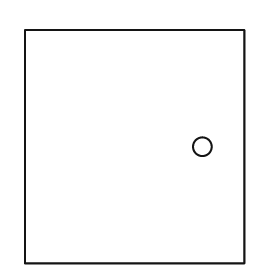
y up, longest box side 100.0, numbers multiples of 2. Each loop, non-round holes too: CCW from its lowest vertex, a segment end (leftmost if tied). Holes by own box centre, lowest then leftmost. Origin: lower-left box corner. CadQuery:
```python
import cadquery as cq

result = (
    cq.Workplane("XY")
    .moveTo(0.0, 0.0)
    .lineTo(94.0, 0.0)
    .lineTo(94.0, 100.0)
    .lineTo(0.0, 100.0)
    .close()
    .moveTo(76.0, 50.0)
    .circle(4.0)
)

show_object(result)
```